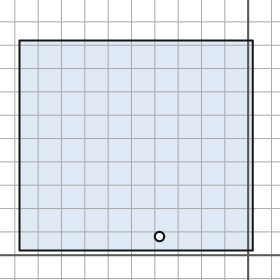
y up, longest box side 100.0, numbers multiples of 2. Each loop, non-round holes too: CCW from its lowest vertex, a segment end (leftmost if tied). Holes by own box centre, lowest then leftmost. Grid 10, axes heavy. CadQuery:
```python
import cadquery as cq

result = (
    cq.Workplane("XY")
    .moveTo(-98.0, 2.0)
    .lineTo(2.0, 2.0)
    .lineTo(2.0, 92.0)
    .lineTo(-98.0, 92.0)
    .close()
    .moveTo(-38.0, 8.0)
    .circle(2.0)
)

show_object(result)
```